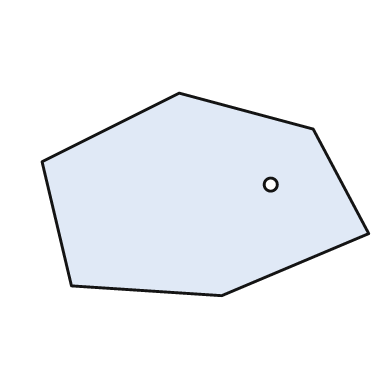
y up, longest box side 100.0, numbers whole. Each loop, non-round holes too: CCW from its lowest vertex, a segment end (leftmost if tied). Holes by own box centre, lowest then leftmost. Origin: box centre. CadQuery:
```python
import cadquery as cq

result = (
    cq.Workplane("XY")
    .moveTo(5.0, -31.0)
    .lineTo(50.0, -12.0)
    .lineTo(33.0, 20.0)
    .lineTo(-8.0, 31.0)
    .lineTo(-50.0, 10.0)
    .lineTo(-41.0, -28.0)
    .close()
    .moveTo(20.0, 3.0)
    .circle(2.0)
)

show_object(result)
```